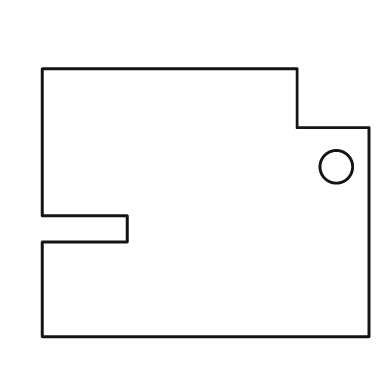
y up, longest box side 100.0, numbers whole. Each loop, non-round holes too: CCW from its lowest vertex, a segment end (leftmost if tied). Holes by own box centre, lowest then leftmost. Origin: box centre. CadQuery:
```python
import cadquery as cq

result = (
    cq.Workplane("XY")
    .moveTo(-50.0, -41.0)
    .lineTo(50.0, -41.0)
    .lineTo(50.0, 23.0)
    .lineTo(28.0, 23.0)
    .lineTo(28.0, 41.0)
    .lineTo(-50.0, 41.0)
    .lineTo(-50.0, -4.0)
    .lineTo(-24.0, -4.0)
    .lineTo(-24.0, -12.0)
    .lineTo(-50.0, -12.0)
    .close()
    .moveTo(40.0, 11.0)
    .circle(5.0)
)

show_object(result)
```